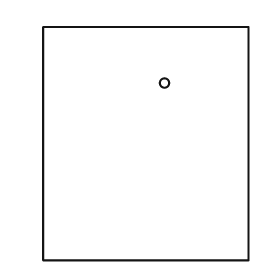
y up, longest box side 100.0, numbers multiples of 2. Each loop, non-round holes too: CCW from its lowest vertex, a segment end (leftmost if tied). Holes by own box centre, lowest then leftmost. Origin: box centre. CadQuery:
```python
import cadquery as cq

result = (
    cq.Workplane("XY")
    .moveTo(-44.0, -50.0)
    .lineTo(44.0, -50.0)
    .lineTo(44.0, 50.0)
    .lineTo(-44.0, 50.0)
    .close()
    .moveTo(8.0, 26.0)
    .circle(2.0)
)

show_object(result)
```